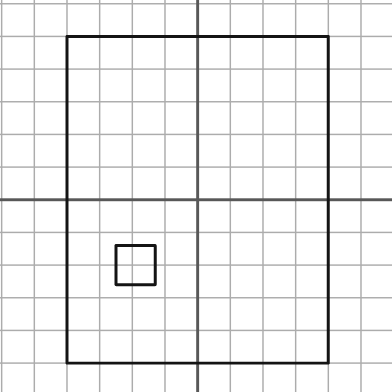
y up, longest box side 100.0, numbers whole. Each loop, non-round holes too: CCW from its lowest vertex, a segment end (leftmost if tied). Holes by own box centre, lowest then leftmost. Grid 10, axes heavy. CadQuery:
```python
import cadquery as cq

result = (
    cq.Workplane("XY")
    .moveTo(-40.0, -50.0)
    .lineTo(40.0, -50.0)
    .lineTo(40.0, 50.0)
    .lineTo(-40.0, 50.0)
    .close()
    .moveTo(-25.0, -26.0)
    .lineTo(-13.0, -26.0)
    .lineTo(-13.0, -14.0)
    .lineTo(-25.0, -14.0)
    .close()
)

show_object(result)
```